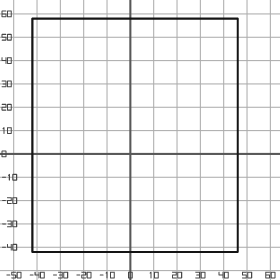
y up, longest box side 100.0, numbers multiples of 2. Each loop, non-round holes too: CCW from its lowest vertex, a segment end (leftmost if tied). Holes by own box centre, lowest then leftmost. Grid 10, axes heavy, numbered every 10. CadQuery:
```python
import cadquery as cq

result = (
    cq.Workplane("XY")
    .moveTo(-42.0, -42.0)
    .lineTo(46.0, -42.0)
    .lineTo(46.0, 58.0)
    .lineTo(-42.0, 58.0)
    .close()
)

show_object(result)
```